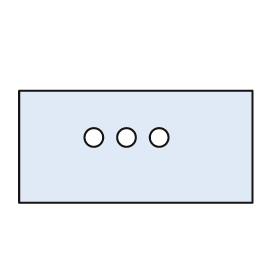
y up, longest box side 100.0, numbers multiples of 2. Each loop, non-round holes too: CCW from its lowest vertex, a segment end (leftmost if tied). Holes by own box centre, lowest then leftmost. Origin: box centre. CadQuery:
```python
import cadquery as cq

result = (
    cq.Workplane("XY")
    .moveTo(-50.0, -24.0)
    .lineTo(50.0, -24.0)
    .lineTo(50.0, 24.0)
    .lineTo(-50.0, 24.0)
    .close()
    .moveTo(-18.0, 4.0)
    .circle(4.0)
    .moveTo(-4.0, 4.0)
    .circle(4.0)
    .moveTo(10.0, 4.0)
    .circle(4.0)
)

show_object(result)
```